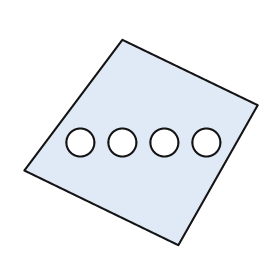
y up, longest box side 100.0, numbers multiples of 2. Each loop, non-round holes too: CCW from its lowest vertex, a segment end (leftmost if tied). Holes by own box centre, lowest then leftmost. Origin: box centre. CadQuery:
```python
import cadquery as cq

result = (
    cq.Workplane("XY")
    .moveTo(16.0, -44.0)
    .lineTo(50.0, 16.0)
    .lineTo(-8.0, 44.0)
    .lineTo(-50.0, -12.0)
    .close()
    .moveTo(-26.0, 0.0)
    .circle(6.0)
    .moveTo(-8.0, 0.0)
    .circle(6.0)
    .moveTo(10.0, 0.0)
    .circle(6.0)
    .moveTo(28.0, 0.0)
    .circle(6.0)
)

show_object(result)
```